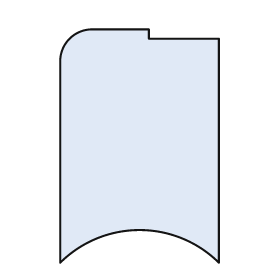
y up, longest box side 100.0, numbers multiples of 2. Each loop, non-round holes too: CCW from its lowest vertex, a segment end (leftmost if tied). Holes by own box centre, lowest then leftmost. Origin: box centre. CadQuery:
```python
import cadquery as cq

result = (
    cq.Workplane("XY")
    .moveTo(-34.0, -50.0)
    .threePointArc((0.0, -36.0), (34.0, -50.0))
    .lineTo(34.0, 46.0)
    .lineTo(4.0, 46.0)
    .lineTo(4.0, 50.0)
    .lineTo(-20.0, 50.0)
    .threePointArc((-30.0, 46.0), (-34.0, 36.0))
    .close()
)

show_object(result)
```